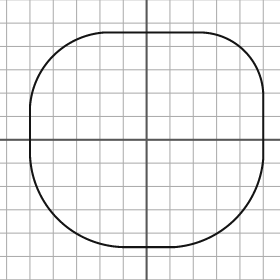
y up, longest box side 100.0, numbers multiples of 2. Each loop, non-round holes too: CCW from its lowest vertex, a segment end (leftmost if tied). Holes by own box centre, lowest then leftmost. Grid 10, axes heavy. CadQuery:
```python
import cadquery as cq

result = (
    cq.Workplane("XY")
    .moveTo(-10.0, -46.0)
    .lineTo(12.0, -46.0)
    .threePointArc((38.0, -34.0), (50.0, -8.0))
    .lineTo(50.0, 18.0)
    .threePointArc((42.0, 38.0), (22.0, 46.0))
    .lineTo(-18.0, 46.0)
    .threePointArc((-40.0, 36.0), (-50.0, 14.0))
    .lineTo(-50.0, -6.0)
    .threePointArc((-38.0, -34.0), (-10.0, -46.0))
    .close()
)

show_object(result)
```